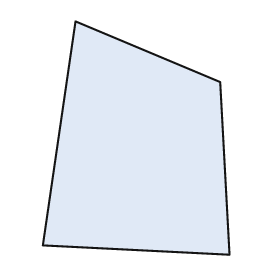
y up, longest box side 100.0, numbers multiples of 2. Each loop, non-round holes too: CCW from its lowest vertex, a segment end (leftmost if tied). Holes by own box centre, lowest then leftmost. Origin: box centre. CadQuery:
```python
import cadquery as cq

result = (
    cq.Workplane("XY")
    .moveTo(40.0, -50.0)
    .lineTo(36.0, 24.0)
    .lineTo(-26.0, 50.0)
    .lineTo(-40.0, -46.0)
    .close()
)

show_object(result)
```